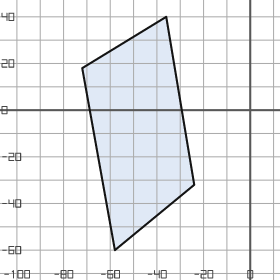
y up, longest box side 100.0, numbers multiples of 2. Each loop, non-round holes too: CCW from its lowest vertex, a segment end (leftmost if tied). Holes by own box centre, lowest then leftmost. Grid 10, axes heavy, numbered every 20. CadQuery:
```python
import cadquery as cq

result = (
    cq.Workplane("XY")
    .moveTo(-58.0, -60.0)
    .lineTo(-24.0, -32.0)
    .lineTo(-36.0, 40.0)
    .lineTo(-72.0, 18.0)
    .close()
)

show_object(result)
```